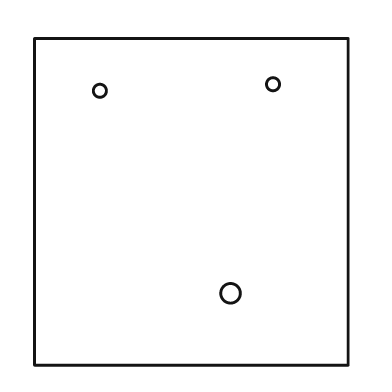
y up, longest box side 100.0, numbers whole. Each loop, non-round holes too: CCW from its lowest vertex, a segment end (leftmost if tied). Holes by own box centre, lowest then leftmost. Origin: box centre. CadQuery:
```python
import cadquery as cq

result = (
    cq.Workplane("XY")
    .moveTo(-48.0, -50.0)
    .lineTo(48.0, -50.0)
    .lineTo(48.0, 50.0)
    .lineTo(-48.0, 50.0)
    .close()
    .moveTo(12.0, -28.0)
    .circle(3.0)
    .moveTo(-28.0, 34.0)
    .circle(2.0)
    .moveTo(25.0, 36.0)
    .circle(2.0)
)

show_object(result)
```